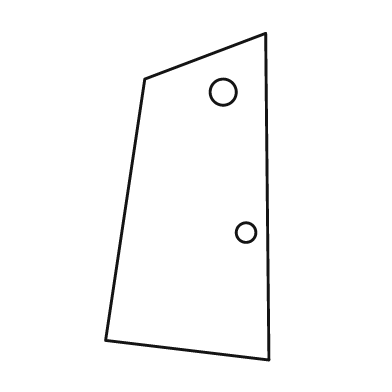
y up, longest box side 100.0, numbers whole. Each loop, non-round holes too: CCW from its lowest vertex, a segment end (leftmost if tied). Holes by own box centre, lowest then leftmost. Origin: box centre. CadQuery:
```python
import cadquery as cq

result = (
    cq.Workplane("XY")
    .moveTo(25.0, -50.0)
    .lineTo(24.0, 50.0)
    .lineTo(-13.0, 36.0)
    .lineTo(-25.0, -44.0)
    .close()
    .moveTo(18.0, -11.0)
    .circle(3.0)
    .moveTo(11.0, 32.0)
    .circle(4.0)
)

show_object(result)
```